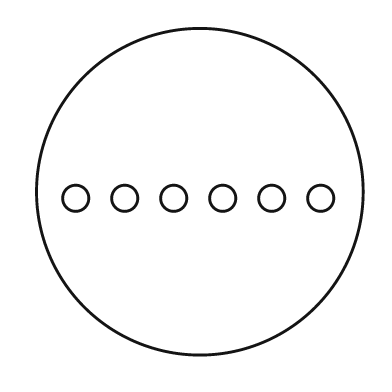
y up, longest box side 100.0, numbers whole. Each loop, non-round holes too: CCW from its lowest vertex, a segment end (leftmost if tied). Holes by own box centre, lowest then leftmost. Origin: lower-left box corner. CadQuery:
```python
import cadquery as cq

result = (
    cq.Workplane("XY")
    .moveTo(50.0, 50.0)
    .circle(50.0)
    .moveTo(12.0, 48.0)
    .circle(4.0)
    .moveTo(27.0, 48.0)
    .circle(4.0)
    .moveTo(42.0, 48.0)
    .circle(4.0)
    .moveTo(57.0, 48.0)
    .circle(4.0)
    .moveTo(72.0, 48.0)
    .circle(4.0)
    .moveTo(87.0, 48.0)
    .circle(4.0)
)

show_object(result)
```